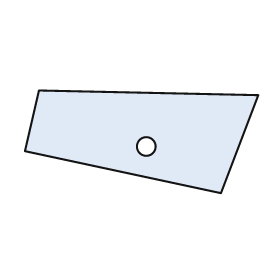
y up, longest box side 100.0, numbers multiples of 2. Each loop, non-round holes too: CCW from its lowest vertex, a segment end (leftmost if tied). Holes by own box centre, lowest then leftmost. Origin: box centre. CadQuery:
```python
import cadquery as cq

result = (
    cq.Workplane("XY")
    .moveTo(34.0, -22.0)
    .lineTo(50.0, 20.0)
    .lineTo(-44.0, 22.0)
    .lineTo(-50.0, -4.0)
    .close()
    .moveTo(2.0, -2.0)
    .circle(4.0)
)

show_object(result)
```